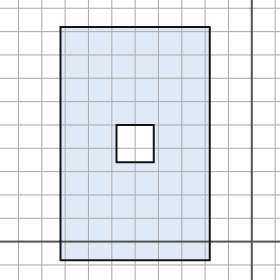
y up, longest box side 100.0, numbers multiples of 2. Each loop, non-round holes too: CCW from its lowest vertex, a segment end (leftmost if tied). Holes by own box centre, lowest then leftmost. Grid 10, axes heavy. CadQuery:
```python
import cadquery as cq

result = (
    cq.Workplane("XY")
    .moveTo(-82.0, -8.0)
    .lineTo(-18.0, -8.0)
    .lineTo(-18.0, 92.0)
    .lineTo(-82.0, 92.0)
    .close()
    .moveTo(-58.0, 34.0)
    .lineTo(-42.0, 34.0)
    .lineTo(-42.0, 50.0)
    .lineTo(-58.0, 50.0)
    .close()
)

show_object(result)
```